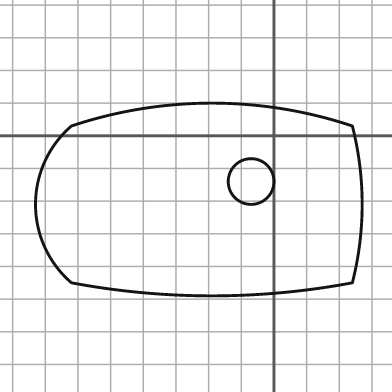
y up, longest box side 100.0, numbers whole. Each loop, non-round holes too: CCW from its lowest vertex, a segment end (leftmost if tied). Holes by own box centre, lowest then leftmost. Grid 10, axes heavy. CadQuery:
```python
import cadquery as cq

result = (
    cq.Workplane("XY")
    .moveTo(-62.0, -45.0)
    .threePointArc((-19.0, -49.0), (24.0, -45.0))
    .threePointArc((27.0, -21.0), (24.0, 3.0))
    .threePointArc((-19.0, 10.0), (-62.0, 3.0))
    .threePointArc((-73.0, -21.0), (-62.0, -45.0))
    .close()
    .moveTo(-7.0, -14.0)
    .circle(7.0)
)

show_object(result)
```